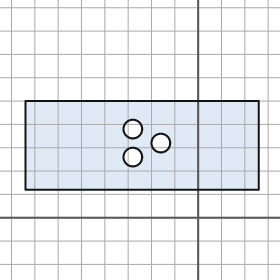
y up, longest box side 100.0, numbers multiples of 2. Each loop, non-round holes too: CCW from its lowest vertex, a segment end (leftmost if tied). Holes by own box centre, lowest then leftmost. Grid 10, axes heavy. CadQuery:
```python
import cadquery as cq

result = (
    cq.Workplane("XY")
    .moveTo(-74.0, 12.0)
    .lineTo(26.0, 12.0)
    .lineTo(26.0, 50.0)
    .lineTo(-74.0, 50.0)
    .close()
    .moveTo(-28.0, 26.0)
    .circle(4.0)
    .moveTo(-16.0, 32.0)
    .circle(4.0)
    .moveTo(-28.0, 38.0)
    .circle(4.0)
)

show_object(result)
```